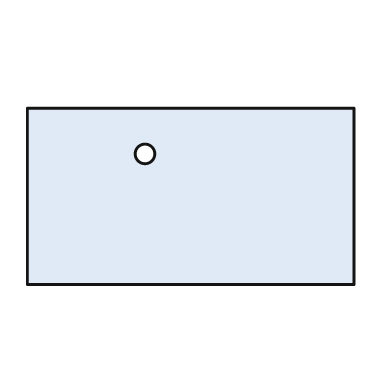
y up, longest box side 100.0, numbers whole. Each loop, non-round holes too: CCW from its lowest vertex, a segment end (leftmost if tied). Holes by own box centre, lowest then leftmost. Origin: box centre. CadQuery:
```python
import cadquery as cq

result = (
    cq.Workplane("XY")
    .moveTo(-50.0, -27.0)
    .lineTo(50.0, -27.0)
    .lineTo(50.0, 27.0)
    .lineTo(-50.0, 27.0)
    .close()
    .moveTo(-14.0, 13.0)
    .circle(3.0)
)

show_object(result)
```